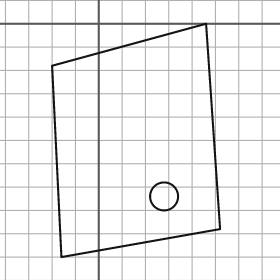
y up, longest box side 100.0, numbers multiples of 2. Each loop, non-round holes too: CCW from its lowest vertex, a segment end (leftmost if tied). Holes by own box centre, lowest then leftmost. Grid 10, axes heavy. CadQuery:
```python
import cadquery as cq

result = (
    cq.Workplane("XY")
    .moveTo(-16.0, -100.0)
    .lineTo(52.0, -88.0)
    .lineTo(46.0, 0.0)
    .lineTo(-20.0, -18.0)
    .close()
    .moveTo(28.0, -74.0)
    .circle(6.0)
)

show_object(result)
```